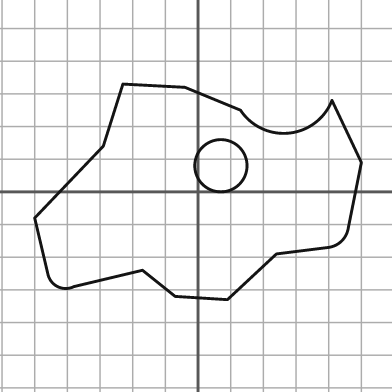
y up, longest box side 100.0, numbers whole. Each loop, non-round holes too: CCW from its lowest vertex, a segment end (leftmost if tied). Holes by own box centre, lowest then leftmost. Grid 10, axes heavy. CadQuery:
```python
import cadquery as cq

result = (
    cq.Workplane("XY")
    .moveTo(9.0, -33.0)
    .lineTo(24.0, -19.0)
    .lineTo(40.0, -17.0)
    .threePointArc((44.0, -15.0), (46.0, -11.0))
    .lineTo(50.0, 9.0)
    .lineTo(41.0, 28.0)
    .threePointArc((28.0, 18.0), (13.0, 25.0))
    .lineTo(-4.0, 32.0)
    .lineTo(-23.0, 33.0)
    .lineTo(-29.0, 14.0)
    .lineTo(-50.0, -8.0)
    .lineTo(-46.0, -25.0)
    .threePointArc((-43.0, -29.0), (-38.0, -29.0))
    .lineTo(-17.0, -24.0)
    .lineTo(-7.0, -32.0)
    .close()
    .moveTo(7.0, 8.0)
    .circle(8.0)
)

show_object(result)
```